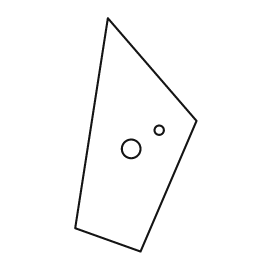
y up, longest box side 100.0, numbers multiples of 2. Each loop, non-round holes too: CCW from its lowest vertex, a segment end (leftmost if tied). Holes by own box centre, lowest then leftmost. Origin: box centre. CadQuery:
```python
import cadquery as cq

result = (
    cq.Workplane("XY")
    .moveTo(2.0, -50.0)
    .lineTo(26.0, 6.0)
    .lineTo(-12.0, 50.0)
    .lineTo(-26.0, -40.0)
    .close()
    .moveTo(-2.0, -6.0)
    .circle(4.0)
    .moveTo(10.0, 2.0)
    .circle(2.0)
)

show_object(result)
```